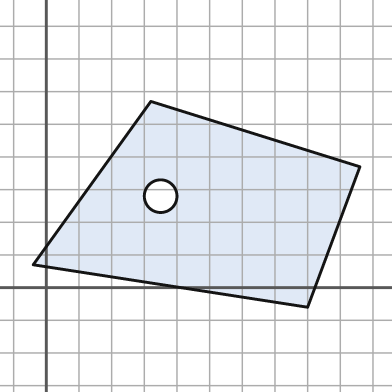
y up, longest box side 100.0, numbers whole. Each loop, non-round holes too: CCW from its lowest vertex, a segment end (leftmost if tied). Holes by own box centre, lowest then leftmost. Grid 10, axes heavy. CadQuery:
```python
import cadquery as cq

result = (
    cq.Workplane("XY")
    .moveTo(80.0, -6.0)
    .lineTo(96.0, 37.0)
    .lineTo(32.0, 57.0)
    .lineTo(-4.0, 7.0)
    .close()
    .moveTo(35.0, 28.0)
    .circle(5.0)
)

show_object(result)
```